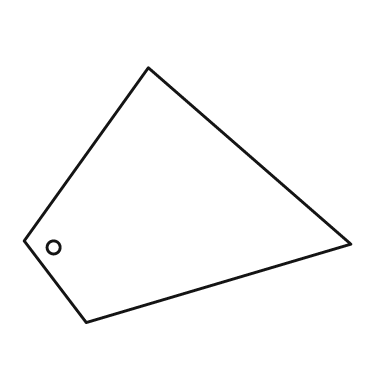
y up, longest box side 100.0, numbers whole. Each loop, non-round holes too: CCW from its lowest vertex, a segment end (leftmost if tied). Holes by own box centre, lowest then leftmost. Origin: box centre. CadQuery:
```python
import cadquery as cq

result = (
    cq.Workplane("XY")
    .moveTo(-31.0, -39.0)
    .lineTo(50.0, -15.0)
    .lineTo(-12.0, 39.0)
    .lineTo(-50.0, -14.0)
    .close()
    .moveTo(-41.0, -16.0)
    .circle(2.0)
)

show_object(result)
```